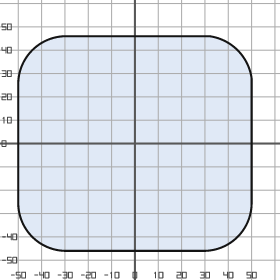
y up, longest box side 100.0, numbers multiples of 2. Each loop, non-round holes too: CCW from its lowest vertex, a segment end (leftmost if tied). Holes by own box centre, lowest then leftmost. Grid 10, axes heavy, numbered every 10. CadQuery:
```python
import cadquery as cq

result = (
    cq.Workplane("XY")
    .moveTo(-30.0, -46.0)
    .lineTo(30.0, -46.0)
    .threePointArc((44.0, -40.0), (50.0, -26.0))
    .lineTo(50.0, 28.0)
    .threePointArc((44.0, 40.0), (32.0, 46.0))
    .lineTo(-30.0, 46.0)
    .threePointArc((-44.0, 40.0), (-50.0, 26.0))
    .lineTo(-50.0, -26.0)
    .threePointArc((-44.0, -40.0), (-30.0, -46.0))
    .close()
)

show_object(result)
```